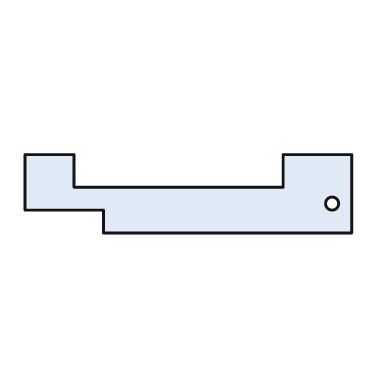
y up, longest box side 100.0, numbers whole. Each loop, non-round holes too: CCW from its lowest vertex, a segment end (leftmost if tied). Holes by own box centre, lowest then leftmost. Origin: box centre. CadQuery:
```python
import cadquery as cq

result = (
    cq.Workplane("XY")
    .moveTo(-26.0, -12.0)
    .lineTo(50.0, -12.0)
    .lineTo(50.0, 12.0)
    .lineTo(29.0, 12.0)
    .lineTo(29.0, 2.0)
    .lineTo(-35.0, 2.0)
    .lineTo(-35.0, 12.0)
    .lineTo(-50.0, 12.0)
    .lineTo(-50.0, -5.0)
    .lineTo(-26.0, -5.0)
    .close()
    .moveTo(44.0, -3.0)
    .circle(2.0)
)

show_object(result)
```